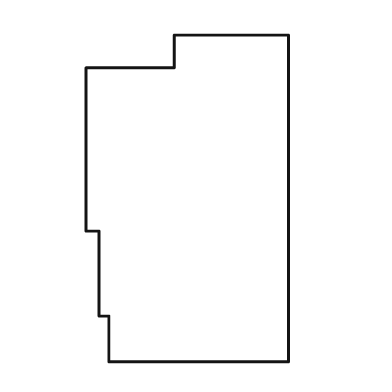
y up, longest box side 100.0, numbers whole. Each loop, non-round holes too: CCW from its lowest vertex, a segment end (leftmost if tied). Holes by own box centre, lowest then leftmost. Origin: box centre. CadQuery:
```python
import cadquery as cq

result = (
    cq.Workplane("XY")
    .moveTo(-24.0, -50.0)
    .lineTo(31.0, -50.0)
    .lineTo(31.0, 50.0)
    .lineTo(-4.0, 50.0)
    .lineTo(-4.0, 40.0)
    .lineTo(-31.0, 40.0)
    .lineTo(-31.0, -10.0)
    .lineTo(-27.0, -10.0)
    .lineTo(-27.0, -36.0)
    .lineTo(-24.0, -36.0)
    .close()
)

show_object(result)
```